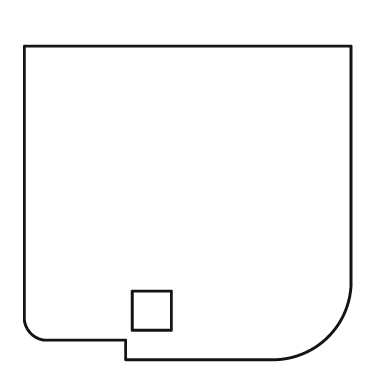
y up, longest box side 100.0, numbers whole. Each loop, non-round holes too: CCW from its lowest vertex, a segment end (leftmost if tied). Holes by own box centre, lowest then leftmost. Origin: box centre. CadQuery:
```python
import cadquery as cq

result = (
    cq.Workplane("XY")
    .moveTo(-19.0, -48.0)
    .lineTo(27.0, -48.0)
    .threePointArc((43.0, -41.0), (50.0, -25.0))
    .lineTo(50.0, 48.0)
    .lineTo(-50.0, 48.0)
    .lineTo(-50.0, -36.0)
    .threePointArc((-48.0, -40.0), (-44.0, -42.0))
    .lineTo(-19.0, -42.0)
    .close()
    .moveTo(-17.0, -39.0)
    .lineTo(-5.0, -39.0)
    .lineTo(-5.0, -27.0)
    .lineTo(-17.0, -27.0)
    .close()
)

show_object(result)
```